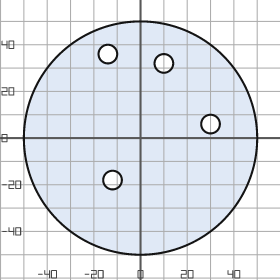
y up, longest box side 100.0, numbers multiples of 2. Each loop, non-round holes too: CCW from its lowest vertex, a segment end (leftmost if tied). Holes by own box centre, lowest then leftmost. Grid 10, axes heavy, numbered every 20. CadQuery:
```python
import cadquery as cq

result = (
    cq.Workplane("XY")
    .moveTo(0.0, 0.0)
    .circle(50.0)
    .moveTo(-12.0, -18.0)
    .circle(4.0)
    .moveTo(30.0, 6.0)
    .circle(4.0)
    .moveTo(10.0, 32.0)
    .circle(4.0)
    .moveTo(-14.0, 36.0)
    .circle(4.0)
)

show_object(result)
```